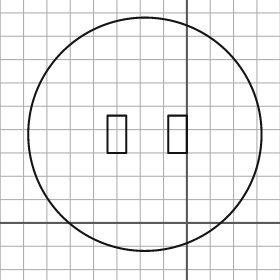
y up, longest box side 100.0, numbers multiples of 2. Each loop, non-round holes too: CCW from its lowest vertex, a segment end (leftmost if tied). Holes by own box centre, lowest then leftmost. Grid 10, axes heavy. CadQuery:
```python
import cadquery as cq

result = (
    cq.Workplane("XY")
    .moveTo(-18.0, 38.0)
    .circle(50.0)
    .moveTo(-34.0, 30.0)
    .lineTo(-26.0, 30.0)
    .lineTo(-26.0, 46.0)
    .lineTo(-34.0, 46.0)
    .close()
    .moveTo(-8.0, 30.0)
    .lineTo(0.0, 30.0)
    .lineTo(0.0, 46.0)
    .lineTo(-8.0, 46.0)
    .close()
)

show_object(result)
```